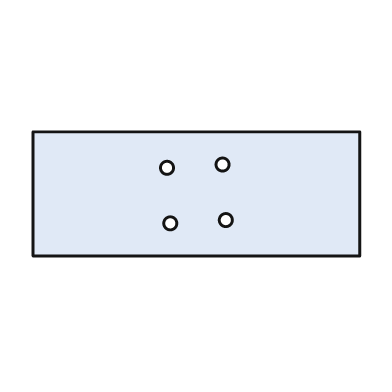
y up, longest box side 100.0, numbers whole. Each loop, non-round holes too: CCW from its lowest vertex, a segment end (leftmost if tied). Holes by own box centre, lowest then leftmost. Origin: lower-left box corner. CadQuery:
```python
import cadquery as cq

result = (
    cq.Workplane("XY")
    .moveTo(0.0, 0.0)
    .lineTo(100.0, 0.0)
    .lineTo(100.0, 38.0)
    .lineTo(0.0, 38.0)
    .close()
    .moveTo(42.0, 10.0)
    .circle(2.0)
    .moveTo(59.0, 11.0)
    .circle(2.0)
    .moveTo(41.0, 27.0)
    .circle(2.0)
    .moveTo(58.0, 28.0)
    .circle(2.0)
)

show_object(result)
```